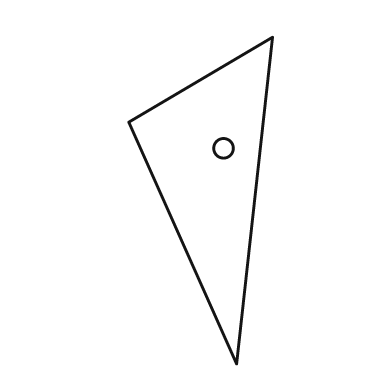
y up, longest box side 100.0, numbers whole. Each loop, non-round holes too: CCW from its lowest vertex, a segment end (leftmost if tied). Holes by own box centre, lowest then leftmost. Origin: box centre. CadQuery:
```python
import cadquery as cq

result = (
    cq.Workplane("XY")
    .moveTo(11.0, -50.0)
    .lineTo(22.0, 50.0)
    .lineTo(-22.0, 24.0)
    .close()
    .moveTo(7.0, 16.0)
    .circle(3.0)
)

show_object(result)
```